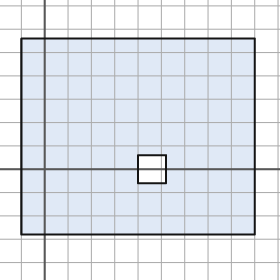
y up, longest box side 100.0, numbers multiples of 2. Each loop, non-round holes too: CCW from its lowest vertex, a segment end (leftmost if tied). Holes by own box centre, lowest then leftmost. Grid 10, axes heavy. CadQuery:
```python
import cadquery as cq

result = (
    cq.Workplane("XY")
    .moveTo(-10.0, -28.0)
    .lineTo(90.0, -28.0)
    .lineTo(90.0, 56.0)
    .lineTo(-10.0, 56.0)
    .close()
    .moveTo(40.0, -6.0)
    .lineTo(52.0, -6.0)
    .lineTo(52.0, 6.0)
    .lineTo(40.0, 6.0)
    .close()
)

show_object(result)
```